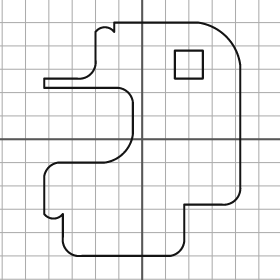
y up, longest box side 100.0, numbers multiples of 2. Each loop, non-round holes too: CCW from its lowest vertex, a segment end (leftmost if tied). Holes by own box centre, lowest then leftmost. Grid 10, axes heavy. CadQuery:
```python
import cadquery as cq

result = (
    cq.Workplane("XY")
    .moveTo(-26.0, -50.0)
    .lineTo(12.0, -50.0)
    .threePointArc((16.0, -48.0), (18.0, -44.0))
    .lineTo(18.0, -28.0)
    .lineTo(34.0, -28.0)
    .threePointArc((40.0, -26.0), (42.0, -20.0))
    .lineTo(42.0, 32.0)
    .threePointArc((36.0, 44.0), (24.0, 50.0))
    .lineTo(-12.0, 50.0)
    .lineTo(-12.0, 46.0)
    .threePointArc((-16.0, 48.0), (-20.0, 46.0))
    .lineTo(-20.0, 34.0)
    .threePointArc((-22.0, 28.0), (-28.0, 26.0))
    .lineTo(-42.0, 26.0)
    .lineTo(-42.0, 22.0)
    .lineTo(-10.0, 22.0)
    .threePointArc((-6.0, 20.0), (-4.0, 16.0))
    .lineTo(-4.0, 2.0)
    .threePointArc((-8.0, -6.0), (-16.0, -10.0))
    .lineTo(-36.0, -10.0)
    .threePointArc((-40.0, -12.0), (-42.0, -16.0))
    .lineTo(-42.0, -32.0)
    .threePointArc((-38.0, -34.0), (-34.0, -32.0))
    .lineTo(-34.0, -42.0)
    .threePointArc((-32.0, -48.0), (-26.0, -50.0))
    .close()
    .moveTo(14.0, 26.0)
    .lineTo(26.0, 26.0)
    .lineTo(26.0, 38.0)
    .lineTo(14.0, 38.0)
    .close()
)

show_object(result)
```